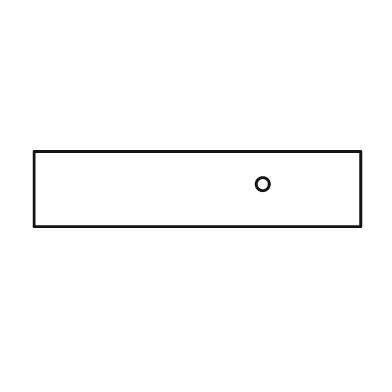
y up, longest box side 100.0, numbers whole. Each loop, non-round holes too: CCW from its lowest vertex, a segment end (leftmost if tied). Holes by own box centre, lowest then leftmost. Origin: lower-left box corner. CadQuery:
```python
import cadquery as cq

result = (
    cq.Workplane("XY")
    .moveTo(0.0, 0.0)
    .lineTo(100.0, 0.0)
    .lineTo(100.0, 23.0)
    .lineTo(0.0, 23.0)
    .close()
    .moveTo(70.0, 13.0)
    .circle(2.0)
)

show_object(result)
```